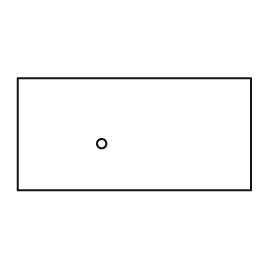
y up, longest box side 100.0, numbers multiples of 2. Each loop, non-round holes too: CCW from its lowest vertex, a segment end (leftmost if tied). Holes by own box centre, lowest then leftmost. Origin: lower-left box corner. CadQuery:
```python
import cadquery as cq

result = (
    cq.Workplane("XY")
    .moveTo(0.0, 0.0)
    .lineTo(100.0, 0.0)
    .lineTo(100.0, 48.0)
    .lineTo(0.0, 48.0)
    .close()
    .moveTo(36.0, 20.0)
    .circle(2.0)
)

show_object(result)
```